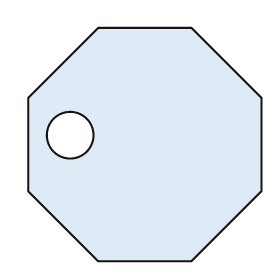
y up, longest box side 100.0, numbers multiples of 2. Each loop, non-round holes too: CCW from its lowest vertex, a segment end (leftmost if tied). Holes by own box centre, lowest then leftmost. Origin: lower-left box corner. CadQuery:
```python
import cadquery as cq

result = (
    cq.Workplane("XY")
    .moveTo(30.0, 0.0)
    .lineTo(70.0, 0.0)
    .lineTo(100.0, 30.0)
    .lineTo(100.0, 70.0)
    .lineTo(70.0, 100.0)
    .lineTo(30.0, 100.0)
    .lineTo(0.0, 70.0)
    .lineTo(0.0, 30.0)
    .close()
    .moveTo(18.0, 54.0)
    .circle(10.0)
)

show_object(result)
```